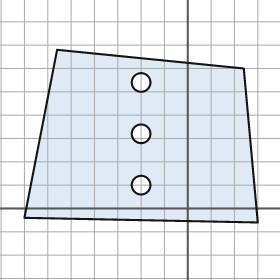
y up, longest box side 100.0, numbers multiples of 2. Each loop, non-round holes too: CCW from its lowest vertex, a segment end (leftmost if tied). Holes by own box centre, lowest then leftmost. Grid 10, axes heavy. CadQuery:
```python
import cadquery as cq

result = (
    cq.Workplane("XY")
    .moveTo(30.0, -6.0)
    .lineTo(24.0, 60.0)
    .lineTo(-56.0, 68.0)
    .lineTo(-70.0, -4.0)
    .close()
    .moveTo(-20.0, 10.0)
    .circle(4.0)
    .moveTo(-20.0, 32.0)
    .circle(4.0)
    .moveTo(-20.0, 54.0)
    .circle(4.0)
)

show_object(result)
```